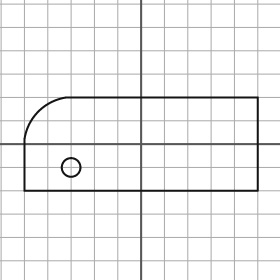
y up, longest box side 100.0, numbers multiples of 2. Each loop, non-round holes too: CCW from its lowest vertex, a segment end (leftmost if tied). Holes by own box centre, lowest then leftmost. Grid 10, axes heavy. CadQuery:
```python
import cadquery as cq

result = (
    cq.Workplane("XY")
    .moveTo(-50.0, -20.0)
    .lineTo(50.0, -20.0)
    .lineTo(50.0, 20.0)
    .lineTo(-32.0, 20.0)
    .threePointArc((-44.0, 14.0), (-50.0, 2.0))
    .close()
    .moveTo(-30.0, -10.0)
    .circle(4.0)
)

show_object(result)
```